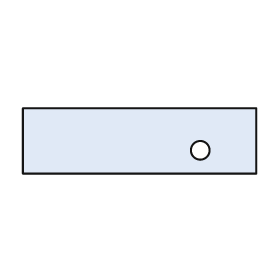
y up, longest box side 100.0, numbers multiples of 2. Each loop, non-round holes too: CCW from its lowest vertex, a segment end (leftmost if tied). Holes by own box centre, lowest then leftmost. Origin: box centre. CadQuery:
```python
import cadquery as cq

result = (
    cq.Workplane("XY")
    .moveTo(-50.0, -14.0)
    .lineTo(50.0, -14.0)
    .lineTo(50.0, 14.0)
    .lineTo(-50.0, 14.0)
    .close()
    .moveTo(26.0, -4.0)
    .circle(4.0)
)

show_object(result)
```